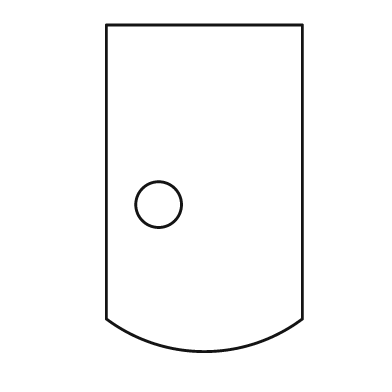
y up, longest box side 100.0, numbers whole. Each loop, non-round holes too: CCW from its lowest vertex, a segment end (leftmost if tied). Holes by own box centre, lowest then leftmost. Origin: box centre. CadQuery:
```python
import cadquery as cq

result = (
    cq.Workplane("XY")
    .moveTo(-30.0, -40.0)
    .threePointArc((0.0, -50.0), (30.0, -40.0))
    .lineTo(30.0, 50.0)
    .lineTo(-30.0, 50.0)
    .close()
    .moveTo(-14.0, -5.0)
    .circle(7.0)
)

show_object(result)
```